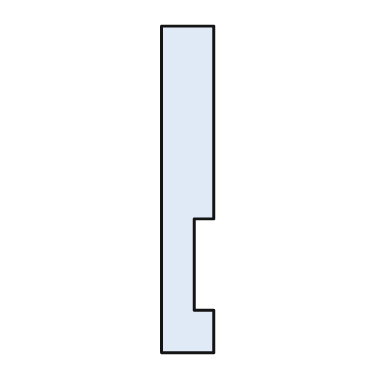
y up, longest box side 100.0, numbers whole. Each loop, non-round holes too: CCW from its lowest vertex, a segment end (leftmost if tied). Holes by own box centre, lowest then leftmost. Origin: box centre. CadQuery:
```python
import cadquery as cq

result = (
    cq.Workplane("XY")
    .moveTo(-8.0, -50.0)
    .lineTo(8.0, -50.0)
    .lineTo(8.0, -37.0)
    .lineTo(2.0, -37.0)
    .lineTo(2.0, -9.0)
    .lineTo(8.0, -9.0)
    .lineTo(8.0, 50.0)
    .lineTo(-8.0, 50.0)
    .close()
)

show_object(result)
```